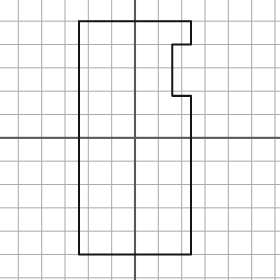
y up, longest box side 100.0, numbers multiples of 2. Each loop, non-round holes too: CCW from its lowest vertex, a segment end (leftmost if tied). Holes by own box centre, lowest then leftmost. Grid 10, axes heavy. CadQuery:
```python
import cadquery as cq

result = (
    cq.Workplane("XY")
    .moveTo(-24.0, -50.0)
    .lineTo(24.0, -50.0)
    .lineTo(24.0, 18.0)
    .lineTo(16.0, 18.0)
    .lineTo(16.0, 40.0)
    .lineTo(24.0, 40.0)
    .lineTo(24.0, 50.0)
    .lineTo(-24.0, 50.0)
    .close()
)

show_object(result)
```